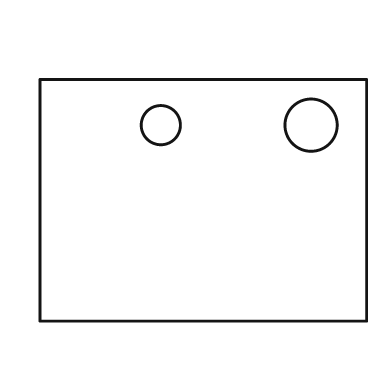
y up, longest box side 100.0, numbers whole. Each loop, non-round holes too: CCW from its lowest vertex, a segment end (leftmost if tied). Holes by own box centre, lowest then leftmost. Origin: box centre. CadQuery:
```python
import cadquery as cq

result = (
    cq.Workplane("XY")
    .moveTo(-50.0, -37.0)
    .lineTo(50.0, -37.0)
    .lineTo(50.0, 37.0)
    .lineTo(-50.0, 37.0)
    .close()
    .moveTo(-13.0, 23.0)
    .circle(6.0)
    .moveTo(33.0, 23.0)
    .circle(8.0)
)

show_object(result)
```